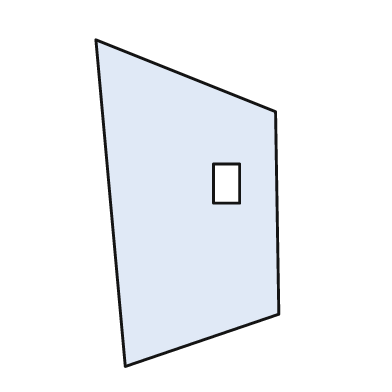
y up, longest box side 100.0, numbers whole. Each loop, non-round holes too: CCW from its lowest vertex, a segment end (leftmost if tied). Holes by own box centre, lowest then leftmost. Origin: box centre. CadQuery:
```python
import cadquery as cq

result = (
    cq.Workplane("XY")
    .moveTo(-19.0, -50.0)
    .lineTo(28.0, -34.0)
    .lineTo(27.0, 28.0)
    .lineTo(-28.0, 50.0)
    .close()
    .moveTo(8.0, 0.0)
    .lineTo(16.0, 0.0)
    .lineTo(16.0, 12.0)
    .lineTo(8.0, 12.0)
    .close()
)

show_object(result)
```